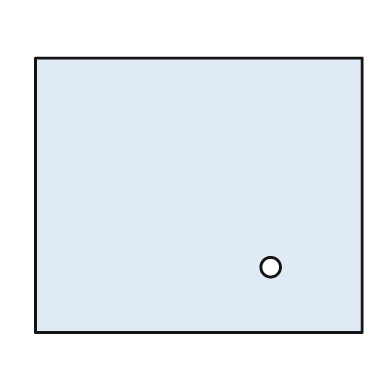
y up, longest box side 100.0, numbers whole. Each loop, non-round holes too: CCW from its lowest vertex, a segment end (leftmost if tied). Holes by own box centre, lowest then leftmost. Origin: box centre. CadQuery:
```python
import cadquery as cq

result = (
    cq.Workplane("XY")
    .moveTo(-50.0, -42.0)
    .lineTo(50.0, -42.0)
    .lineTo(50.0, 42.0)
    .lineTo(-50.0, 42.0)
    .close()
    .moveTo(22.0, -22.0)
    .circle(3.0)
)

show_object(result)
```